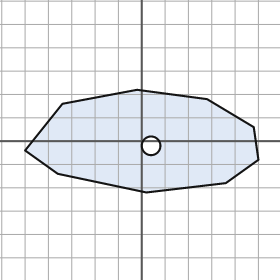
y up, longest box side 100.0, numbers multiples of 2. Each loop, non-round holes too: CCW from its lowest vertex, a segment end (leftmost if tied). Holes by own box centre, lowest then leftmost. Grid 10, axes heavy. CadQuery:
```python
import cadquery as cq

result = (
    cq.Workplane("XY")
    .moveTo(2.0, -22.0)
    .lineTo(36.0, -18.0)
    .lineTo(50.0, -8.0)
    .lineTo(48.0, 6.0)
    .lineTo(28.0, 18.0)
    .lineTo(-2.0, 22.0)
    .lineTo(-34.0, 16.0)
    .lineTo(-50.0, -4.0)
    .lineTo(-36.0, -14.0)
    .close()
    .moveTo(4.0, -2.0)
    .circle(4.0)
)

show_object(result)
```